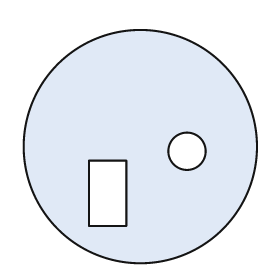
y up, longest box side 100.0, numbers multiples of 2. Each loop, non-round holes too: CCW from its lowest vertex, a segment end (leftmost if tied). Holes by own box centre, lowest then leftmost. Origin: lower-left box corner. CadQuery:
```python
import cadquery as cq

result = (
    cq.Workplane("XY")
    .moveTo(50.0, 50.0)
    .circle(50.0)
    .moveTo(28.0, 16.0)
    .lineTo(44.0, 16.0)
    .lineTo(44.0, 44.0)
    .lineTo(28.0, 44.0)
    .close()
    .moveTo(70.0, 48.0)
    .circle(8.0)
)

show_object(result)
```